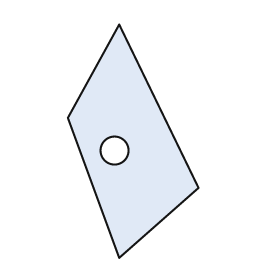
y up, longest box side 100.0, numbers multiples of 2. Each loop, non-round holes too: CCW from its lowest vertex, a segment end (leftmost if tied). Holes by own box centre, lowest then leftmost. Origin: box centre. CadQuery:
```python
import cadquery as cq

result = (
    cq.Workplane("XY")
    .moveTo(-6.0, -50.0)
    .lineTo(28.0, -20.0)
    .lineTo(-6.0, 50.0)
    .lineTo(-28.0, 10.0)
    .close()
    .moveTo(-8.0, -4.0)
    .circle(6.0)
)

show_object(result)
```